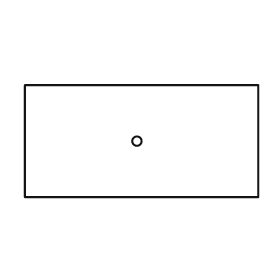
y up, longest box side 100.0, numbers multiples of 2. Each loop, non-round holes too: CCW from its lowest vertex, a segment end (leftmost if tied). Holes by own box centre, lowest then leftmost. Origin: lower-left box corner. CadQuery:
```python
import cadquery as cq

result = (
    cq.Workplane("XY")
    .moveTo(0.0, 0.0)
    .lineTo(100.0, 0.0)
    .lineTo(100.0, 48.0)
    .lineTo(0.0, 48.0)
    .close()
    .moveTo(48.0, 24.0)
    .circle(2.0)
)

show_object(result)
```